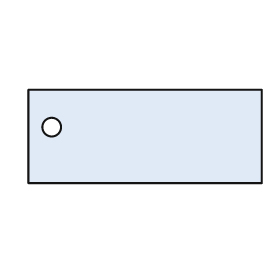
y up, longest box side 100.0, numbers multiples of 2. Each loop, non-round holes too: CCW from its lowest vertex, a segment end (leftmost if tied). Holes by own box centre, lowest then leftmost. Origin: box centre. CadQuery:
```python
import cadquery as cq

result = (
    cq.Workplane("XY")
    .moveTo(-50.0, -20.0)
    .lineTo(50.0, -20.0)
    .lineTo(50.0, 20.0)
    .lineTo(-50.0, 20.0)
    .close()
    .moveTo(-40.0, 4.0)
    .circle(4.0)
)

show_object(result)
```